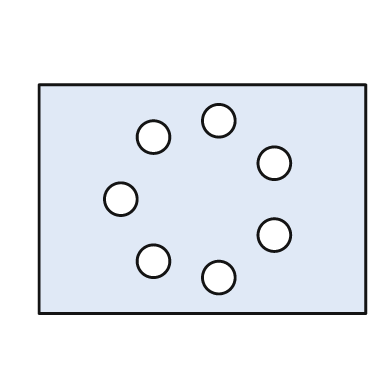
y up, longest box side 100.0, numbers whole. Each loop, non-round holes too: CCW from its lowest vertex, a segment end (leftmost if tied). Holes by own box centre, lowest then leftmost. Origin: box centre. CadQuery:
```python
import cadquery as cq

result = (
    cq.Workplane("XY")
    .moveTo(-50.0, -35.0)
    .lineTo(50.0, -35.0)
    .lineTo(50.0, 35.0)
    .lineTo(-50.0, 35.0)
    .close()
    .moveTo(5.0, -24.0)
    .circle(5.0)
    .moveTo(-15.0, -19.0)
    .circle(5.0)
    .moveTo(22.0, -11.0)
    .circle(5.0)
    .moveTo(-25.0, 0.0)
    .circle(5.0)
    .moveTo(22.0, 11.0)
    .circle(5.0)
    .moveTo(-15.0, 19.0)
    .circle(5.0)
    .moveTo(5.0, 24.0)
    .circle(5.0)
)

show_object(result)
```